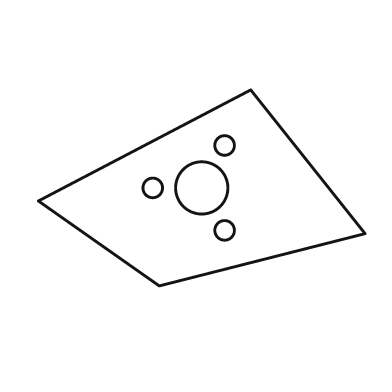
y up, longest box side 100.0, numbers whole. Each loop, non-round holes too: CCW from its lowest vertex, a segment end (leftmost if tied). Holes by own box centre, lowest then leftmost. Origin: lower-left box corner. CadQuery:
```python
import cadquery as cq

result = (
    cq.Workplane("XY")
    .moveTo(37.0, 0.0)
    .lineTo(100.0, 16.0)
    .lineTo(65.0, 60.0)
    .lineTo(0.0, 26.0)
    .close()
    .moveTo(57.0, 17.0)
    .circle(3.0)
    .moveTo(35.0, 30.0)
    .circle(3.0)
    .moveTo(50.0, 30.0)
    .circle(8.0)
    .moveTo(57.0, 43.0)
    .circle(3.0)
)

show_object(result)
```